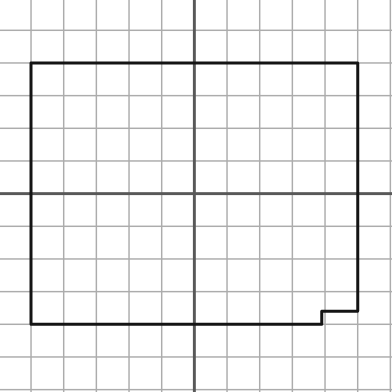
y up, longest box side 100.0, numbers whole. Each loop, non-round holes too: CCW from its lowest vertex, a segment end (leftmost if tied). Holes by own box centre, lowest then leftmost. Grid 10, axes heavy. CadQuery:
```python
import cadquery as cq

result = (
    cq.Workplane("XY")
    .moveTo(-50.0, -40.0)
    .lineTo(39.0, -40.0)
    .lineTo(39.0, -36.0)
    .lineTo(50.0, -36.0)
    .lineTo(50.0, 40.0)
    .lineTo(-50.0, 40.0)
    .close()
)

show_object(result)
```